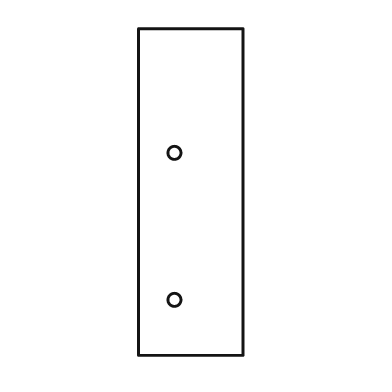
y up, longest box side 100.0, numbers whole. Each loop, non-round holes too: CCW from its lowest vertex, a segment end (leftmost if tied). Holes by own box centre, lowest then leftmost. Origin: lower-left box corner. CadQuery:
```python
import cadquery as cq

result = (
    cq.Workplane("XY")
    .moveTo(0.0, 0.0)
    .lineTo(32.0, 0.0)
    .lineTo(32.0, 100.0)
    .lineTo(0.0, 100.0)
    .close()
    .moveTo(11.0, 17.0)
    .circle(2.0)
    .moveTo(11.0, 62.0)
    .circle(2.0)
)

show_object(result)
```